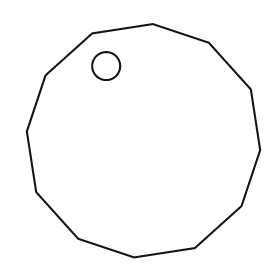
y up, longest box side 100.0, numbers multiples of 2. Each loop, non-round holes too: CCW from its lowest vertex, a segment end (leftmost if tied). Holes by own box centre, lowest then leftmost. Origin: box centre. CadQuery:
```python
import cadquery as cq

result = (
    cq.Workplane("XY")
    .moveTo(-4.0, -50.0)
    .lineTo(22.0, -46.0)
    .lineTo(42.0, -28.0)
    .lineTo(50.0, -4.0)
    .lineTo(46.0, 22.0)
    .lineTo(28.0, 42.0)
    .lineTo(4.0, 50.0)
    .lineTo(-22.0, 46.0)
    .lineTo(-42.0, 28.0)
    .lineTo(-50.0, 4.0)
    .lineTo(-46.0, -22.0)
    .lineTo(-28.0, -42.0)
    .close()
    .moveTo(-16.0, 32.0)
    .circle(6.0)
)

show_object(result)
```